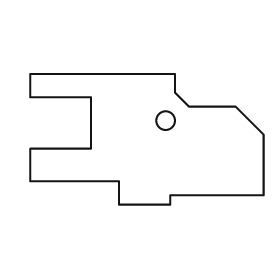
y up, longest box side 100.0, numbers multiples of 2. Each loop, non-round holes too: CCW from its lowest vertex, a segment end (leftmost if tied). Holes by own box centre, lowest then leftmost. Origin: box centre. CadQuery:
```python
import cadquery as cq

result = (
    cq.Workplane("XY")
    .moveTo(-12.0, -28.0)
    .lineTo(10.0, -28.0)
    .lineTo(10.0, -24.0)
    .lineTo(50.0, -24.0)
    .lineTo(50.0, 2.0)
    .lineTo(38.0, 14.0)
    .lineTo(18.0, 14.0)
    .lineTo(12.0, 20.0)
    .lineTo(12.0, 28.0)
    .lineTo(-50.0, 28.0)
    .lineTo(-50.0, 18.0)
    .lineTo(-24.0, 18.0)
    .lineTo(-24.0, -4.0)
    .lineTo(-50.0, -4.0)
    .lineTo(-50.0, -18.0)
    .lineTo(-12.0, -18.0)
    .close()
    .moveTo(8.0, 8.0)
    .circle(4.0)
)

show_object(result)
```